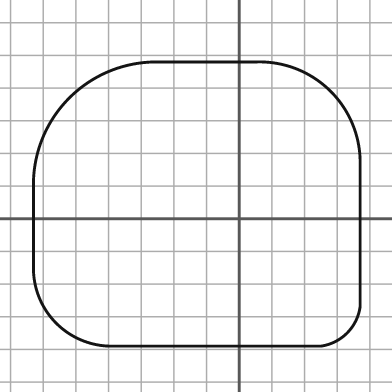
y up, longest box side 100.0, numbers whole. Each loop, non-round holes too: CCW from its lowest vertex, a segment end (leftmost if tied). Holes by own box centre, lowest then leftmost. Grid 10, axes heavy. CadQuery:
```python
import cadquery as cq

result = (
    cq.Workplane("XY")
    .moveTo(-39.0, -39.0)
    .lineTo(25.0, -39.0)
    .threePointArc((33.0, -35.0), (37.0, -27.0))
    .lineTo(37.0, 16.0)
    .threePointArc((28.0, 39.0), (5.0, 48.0))
    .lineTo(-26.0, 48.0)
    .threePointArc((-52.0, 37.0), (-63.0, 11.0))
    .lineTo(-63.0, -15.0)
    .threePointArc((-56.0, -32.0), (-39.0, -39.0))
    .close()
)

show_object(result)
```